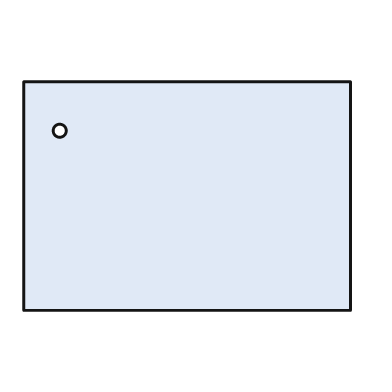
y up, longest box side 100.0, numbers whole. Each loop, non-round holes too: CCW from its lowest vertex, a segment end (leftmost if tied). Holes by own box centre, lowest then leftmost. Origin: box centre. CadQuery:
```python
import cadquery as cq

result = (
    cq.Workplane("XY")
    .moveTo(-50.0, -35.0)
    .lineTo(50.0, -35.0)
    .lineTo(50.0, 35.0)
    .lineTo(-50.0, 35.0)
    .close()
    .moveTo(-39.0, 20.0)
    .circle(2.0)
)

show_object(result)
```